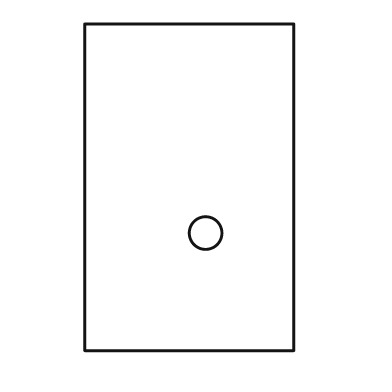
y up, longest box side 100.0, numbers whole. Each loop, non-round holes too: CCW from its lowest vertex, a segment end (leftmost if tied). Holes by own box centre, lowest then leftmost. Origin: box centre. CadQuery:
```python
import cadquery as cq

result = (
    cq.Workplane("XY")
    .moveTo(-32.0, -50.0)
    .lineTo(32.0, -50.0)
    .lineTo(32.0, 50.0)
    .lineTo(-32.0, 50.0)
    .close()
    .moveTo(5.0, -14.0)
    .circle(5.0)
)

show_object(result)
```